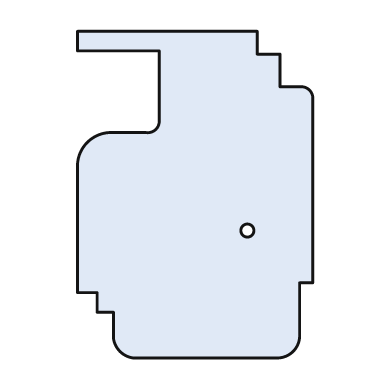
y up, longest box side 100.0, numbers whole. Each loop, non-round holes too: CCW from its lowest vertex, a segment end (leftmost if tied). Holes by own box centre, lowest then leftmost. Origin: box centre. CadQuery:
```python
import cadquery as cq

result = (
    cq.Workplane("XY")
    .moveTo(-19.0, -50.0)
    .lineTo(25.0, -50.0)
    .threePointArc((30.0, -48.0), (32.0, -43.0))
    .lineTo(32.0, -27.0)
    .lineTo(36.0, -27.0)
    .lineTo(36.0, 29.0)
    .threePointArc((35.0, 32.0), (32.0, 33.0))
    .lineTo(26.0, 33.0)
    .lineTo(26.0, 43.0)
    .lineTo(19.0, 43.0)
    .lineTo(19.0, 50.0)
    .lineTo(-36.0, 50.0)
    .lineTo(-36.0, 44.0)
    .lineTo(-11.0, 44.0)
    .lineTo(-11.0, 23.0)
    .threePointArc((-12.0, 20.0), (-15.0, 19.0))
    .lineTo(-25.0, 19.0)
    .threePointArc((-33.0, 16.0), (-36.0, 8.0))
    .lineTo(-36.0, -30.0)
    .lineTo(-30.0, -30.0)
    .lineTo(-30.0, -36.0)
    .lineTo(-25.0, -36.0)
    .lineTo(-25.0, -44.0)
    .threePointArc((-23.0, -48.0), (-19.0, -50.0))
    .close()
    .moveTo(16.0, -11.0)
    .circle(2.0)
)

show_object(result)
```